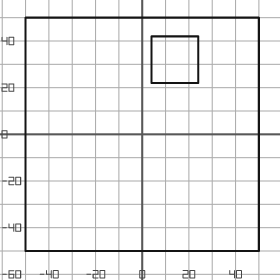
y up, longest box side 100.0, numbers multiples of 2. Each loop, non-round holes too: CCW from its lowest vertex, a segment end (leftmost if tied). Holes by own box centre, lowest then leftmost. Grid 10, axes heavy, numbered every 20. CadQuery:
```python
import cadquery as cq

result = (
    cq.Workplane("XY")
    .moveTo(-50.0, -50.0)
    .lineTo(50.0, -50.0)
    .lineTo(50.0, 50.0)
    .lineTo(-50.0, 50.0)
    .close()
    .moveTo(4.0, 22.0)
    .lineTo(24.0, 22.0)
    .lineTo(24.0, 42.0)
    .lineTo(4.0, 42.0)
    .close()
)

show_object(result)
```